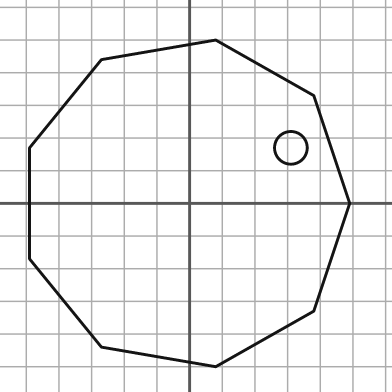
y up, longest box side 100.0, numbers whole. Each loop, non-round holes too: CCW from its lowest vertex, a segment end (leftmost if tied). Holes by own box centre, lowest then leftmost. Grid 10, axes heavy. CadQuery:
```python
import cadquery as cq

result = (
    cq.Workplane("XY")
    .moveTo(8.0, -50.0)
    .lineTo(38.0, -33.0)
    .lineTo(49.0, 0.0)
    .lineTo(38.0, 33.0)
    .lineTo(8.0, 50.0)
    .lineTo(-27.0, 44.0)
    .lineTo(-49.0, 17.0)
    .lineTo(-49.0, -17.0)
    .lineTo(-27.0, -44.0)
    .close()
    .moveTo(31.0, 17.0)
    .circle(5.0)
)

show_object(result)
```